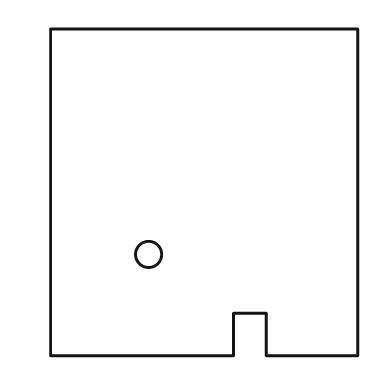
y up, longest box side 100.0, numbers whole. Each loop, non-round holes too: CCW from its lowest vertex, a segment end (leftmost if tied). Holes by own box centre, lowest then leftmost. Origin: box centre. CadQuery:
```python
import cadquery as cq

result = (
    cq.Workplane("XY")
    .moveTo(-47.0, -50.0)
    .lineTo(9.0, -50.0)
    .lineTo(9.0, -37.0)
    .lineTo(19.0, -37.0)
    .lineTo(19.0, -50.0)
    .lineTo(47.0, -50.0)
    .lineTo(47.0, 50.0)
    .lineTo(-47.0, 50.0)
    .close()
    .moveTo(-17.0, -19.0)
    .circle(4.0)
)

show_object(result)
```